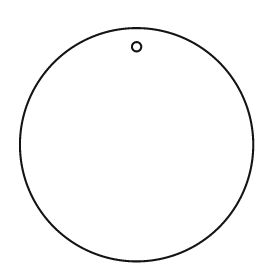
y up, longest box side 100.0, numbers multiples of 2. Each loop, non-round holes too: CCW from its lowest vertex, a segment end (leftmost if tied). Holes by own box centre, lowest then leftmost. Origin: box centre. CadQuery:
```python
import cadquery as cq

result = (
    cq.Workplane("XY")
    .moveTo(0.0, 0.0)
    .circle(50.0)
    .moveTo(0.0, 42.0)
    .circle(2.0)
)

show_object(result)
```